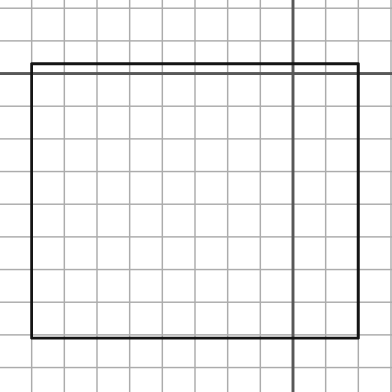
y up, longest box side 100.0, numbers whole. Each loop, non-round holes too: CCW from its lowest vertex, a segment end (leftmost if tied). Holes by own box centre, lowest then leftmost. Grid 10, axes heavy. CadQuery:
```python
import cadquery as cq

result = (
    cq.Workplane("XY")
    .moveTo(-80.0, -81.0)
    .lineTo(20.0, -81.0)
    .lineTo(20.0, 3.0)
    .lineTo(-80.0, 3.0)
    .close()
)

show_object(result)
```